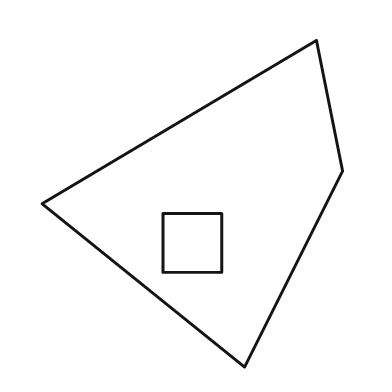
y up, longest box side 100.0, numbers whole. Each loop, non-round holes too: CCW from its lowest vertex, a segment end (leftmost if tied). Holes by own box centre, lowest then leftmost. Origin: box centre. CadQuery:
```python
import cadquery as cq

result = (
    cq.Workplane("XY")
    .moveTo(16.0, -50.0)
    .lineTo(46.0, 10.0)
    .lineTo(38.0, 50.0)
    .lineTo(-46.0, 0.0)
    .close()
    .moveTo(-9.0, -21.0)
    .lineTo(9.0, -21.0)
    .lineTo(9.0, -3.0)
    .lineTo(-9.0, -3.0)
    .close()
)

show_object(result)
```